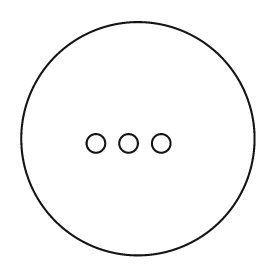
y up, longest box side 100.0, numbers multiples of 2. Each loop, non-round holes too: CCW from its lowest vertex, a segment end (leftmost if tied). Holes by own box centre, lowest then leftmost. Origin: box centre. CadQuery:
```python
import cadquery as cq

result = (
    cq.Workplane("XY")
    .moveTo(0.0, 0.0)
    .circle(50.0)
    .moveTo(-18.0, -2.0)
    .circle(4.0)
    .moveTo(-4.0, -2.0)
    .circle(4.0)
    .moveTo(10.0, -2.0)
    .circle(4.0)
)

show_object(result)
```